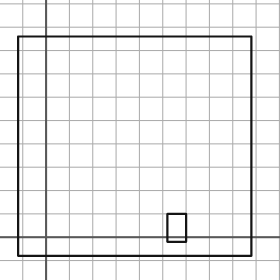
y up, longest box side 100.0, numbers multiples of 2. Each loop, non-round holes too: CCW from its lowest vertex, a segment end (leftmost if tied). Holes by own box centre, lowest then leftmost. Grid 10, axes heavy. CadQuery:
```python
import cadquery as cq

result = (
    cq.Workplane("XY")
    .moveTo(-12.0, -8.0)
    .lineTo(88.0, -8.0)
    .lineTo(88.0, 86.0)
    .lineTo(-12.0, 86.0)
    .close()
    .moveTo(52.0, -2.0)
    .lineTo(60.0, -2.0)
    .lineTo(60.0, 10.0)
    .lineTo(52.0, 10.0)
    .close()
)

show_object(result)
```